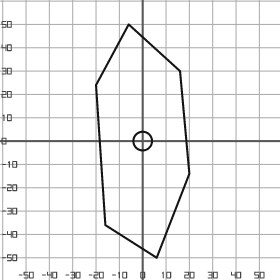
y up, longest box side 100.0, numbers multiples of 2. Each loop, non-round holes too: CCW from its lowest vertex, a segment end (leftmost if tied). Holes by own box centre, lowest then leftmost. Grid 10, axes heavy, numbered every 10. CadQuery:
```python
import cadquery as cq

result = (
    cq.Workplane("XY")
    .moveTo(6.0, -50.0)
    .lineTo(20.0, -14.0)
    .lineTo(16.0, 30.0)
    .lineTo(-6.0, 50.0)
    .lineTo(-20.0, 24.0)
    .lineTo(-16.0, -36.0)
    .close()
    .moveTo(0.0, 0.0)
    .circle(4.0)
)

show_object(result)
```